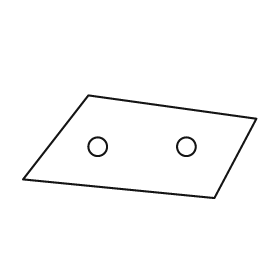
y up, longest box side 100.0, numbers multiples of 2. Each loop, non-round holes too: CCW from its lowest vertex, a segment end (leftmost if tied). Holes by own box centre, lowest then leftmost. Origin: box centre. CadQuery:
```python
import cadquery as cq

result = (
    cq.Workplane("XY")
    .moveTo(32.0, -22.0)
    .lineTo(50.0, 12.0)
    .lineTo(-22.0, 22.0)
    .lineTo(-50.0, -14.0)
    .close()
    .moveTo(-18.0, 0.0)
    .circle(4.0)
    .moveTo(20.0, 0.0)
    .circle(4.0)
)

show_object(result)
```